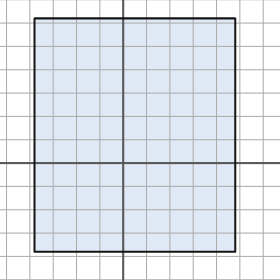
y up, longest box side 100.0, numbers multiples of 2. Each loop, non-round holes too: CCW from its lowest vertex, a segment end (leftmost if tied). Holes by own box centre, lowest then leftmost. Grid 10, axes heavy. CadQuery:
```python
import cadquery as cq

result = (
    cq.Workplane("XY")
    .moveTo(-38.0, -38.0)
    .lineTo(48.0, -38.0)
    .lineTo(48.0, 62.0)
    .lineTo(-38.0, 62.0)
    .close()
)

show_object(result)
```